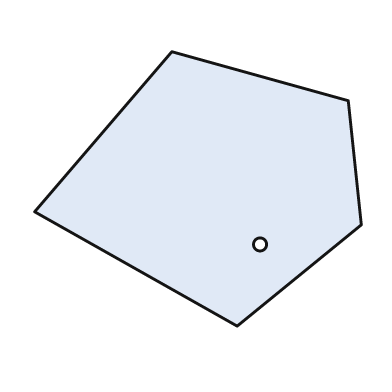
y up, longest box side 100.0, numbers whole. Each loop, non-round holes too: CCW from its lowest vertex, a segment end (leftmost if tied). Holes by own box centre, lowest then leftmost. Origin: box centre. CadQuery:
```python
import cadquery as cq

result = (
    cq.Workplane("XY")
    .moveTo(12.0, -42.0)
    .lineTo(50.0, -11.0)
    .lineTo(46.0, 27.0)
    .lineTo(-8.0, 42.0)
    .lineTo(-50.0, -7.0)
    .close()
    .moveTo(19.0, -17.0)
    .circle(2.0)
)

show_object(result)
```